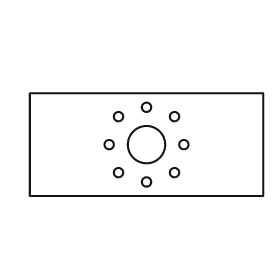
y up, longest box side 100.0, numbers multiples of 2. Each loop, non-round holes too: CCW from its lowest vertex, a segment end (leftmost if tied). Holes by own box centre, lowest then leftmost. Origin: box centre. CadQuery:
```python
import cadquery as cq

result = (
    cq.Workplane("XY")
    .moveTo(-50.0, -22.0)
    .lineTo(50.0, -22.0)
    .lineTo(50.0, 22.0)
    .lineTo(-50.0, 22.0)
    .close()
    .moveTo(0.0, -16.0)
    .circle(2.0)
    .moveTo(-12.0, -12.0)
    .circle(2.0)
    .moveTo(12.0, -12.0)
    .circle(2.0)
    .moveTo(-16.0, 0.0)
    .circle(2.0)
    .moveTo(0.0, 0.0)
    .circle(8.0)
    .moveTo(16.0, 0.0)
    .circle(2.0)
    .moveTo(-12.0, 12.0)
    .circle(2.0)
    .moveTo(12.0, 12.0)
    .circle(2.0)
    .moveTo(0.0, 16.0)
    .circle(2.0)
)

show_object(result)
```